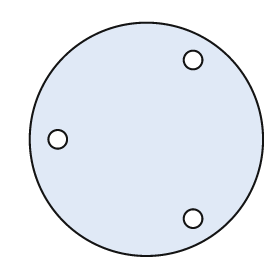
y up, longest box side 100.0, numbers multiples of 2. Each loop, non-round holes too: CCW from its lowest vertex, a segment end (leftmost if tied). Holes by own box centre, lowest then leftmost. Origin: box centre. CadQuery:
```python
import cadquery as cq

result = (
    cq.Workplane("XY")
    .moveTo(0.0, 0.0)
    .circle(50.0)
    .moveTo(20.0, -34.0)
    .circle(4.0)
    .moveTo(-38.0, 0.0)
    .circle(4.0)
    .moveTo(20.0, 34.0)
    .circle(4.0)
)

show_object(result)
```